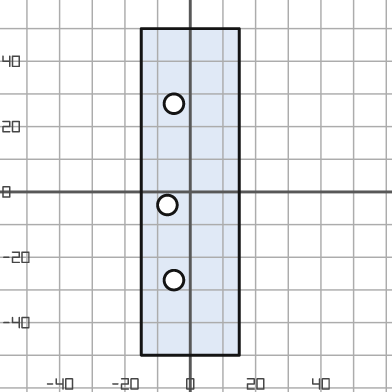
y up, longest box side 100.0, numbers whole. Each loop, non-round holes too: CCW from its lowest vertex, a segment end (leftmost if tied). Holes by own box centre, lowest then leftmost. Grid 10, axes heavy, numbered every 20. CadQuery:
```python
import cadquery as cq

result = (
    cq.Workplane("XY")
    .moveTo(-15.0, -50.0)
    .lineTo(15.0, -50.0)
    .lineTo(15.0, 50.0)
    .lineTo(-15.0, 50.0)
    .close()
    .moveTo(-5.0, -27.0)
    .circle(3.0)
    .moveTo(-7.0, -4.0)
    .circle(3.0)
    .moveTo(-5.0, 27.0)
    .circle(3.0)
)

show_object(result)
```